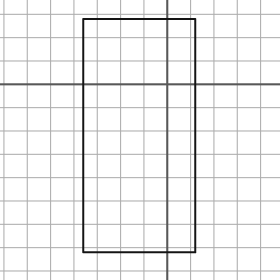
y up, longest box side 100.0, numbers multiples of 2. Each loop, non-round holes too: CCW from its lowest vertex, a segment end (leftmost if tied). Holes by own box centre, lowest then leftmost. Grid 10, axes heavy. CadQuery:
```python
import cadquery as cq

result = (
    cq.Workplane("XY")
    .moveTo(-36.0, -72.0)
    .lineTo(12.0, -72.0)
    .lineTo(12.0, 28.0)
    .lineTo(-36.0, 28.0)
    .close()
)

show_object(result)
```